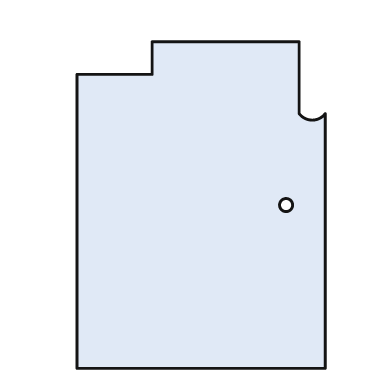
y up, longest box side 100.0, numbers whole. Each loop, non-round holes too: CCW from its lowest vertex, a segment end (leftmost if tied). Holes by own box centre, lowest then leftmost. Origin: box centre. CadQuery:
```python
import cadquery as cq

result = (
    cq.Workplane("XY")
    .moveTo(-38.0, -50.0)
    .lineTo(38.0, -50.0)
    .lineTo(38.0, 28.0)
    .threePointArc((34.0, 26.0), (30.0, 28.0))
    .lineTo(30.0, 50.0)
    .lineTo(-15.0, 50.0)
    .lineTo(-15.0, 40.0)
    .lineTo(-38.0, 40.0)
    .close()
    .moveTo(26.0, 0.0)
    .circle(2.0)
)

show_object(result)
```